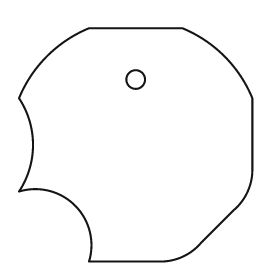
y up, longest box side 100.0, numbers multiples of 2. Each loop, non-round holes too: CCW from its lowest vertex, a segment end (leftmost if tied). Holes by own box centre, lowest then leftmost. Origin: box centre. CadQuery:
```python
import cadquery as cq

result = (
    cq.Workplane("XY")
    .moveTo(-20.0, -50.0)
    .lineTo(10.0, -50.0)
    .threePointArc((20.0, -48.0), (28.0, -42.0))
    .lineTo(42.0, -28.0)
    .threePointArc((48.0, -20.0), (50.0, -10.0))
    .lineTo(50.0, 20.0)
    .threePointArc((38.0, 38.0), (20.0, 50.0))
    .lineTo(-20.0, 50.0)
    .threePointArc((-38.0, 38.0), (-50.0, 20.0))
    .threePointArc((-44.0, 0.0), (-50.0, -20.0))
    .threePointArc((-26.0, -26.0), (-20.0, -50.0))
    .close()
    .moveTo(0.0, 28.0)
    .circle(4.0)
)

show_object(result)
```